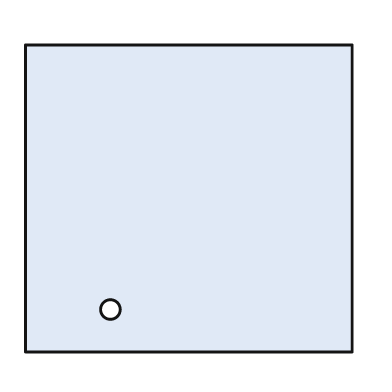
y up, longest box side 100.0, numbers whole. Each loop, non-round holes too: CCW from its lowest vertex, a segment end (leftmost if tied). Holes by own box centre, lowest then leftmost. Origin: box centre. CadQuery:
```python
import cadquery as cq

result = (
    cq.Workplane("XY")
    .moveTo(-50.0, -47.0)
    .lineTo(50.0, -47.0)
    .lineTo(50.0, 47.0)
    .lineTo(-50.0, 47.0)
    .close()
    .moveTo(-24.0, -34.0)
    .circle(3.0)
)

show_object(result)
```